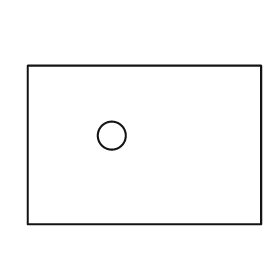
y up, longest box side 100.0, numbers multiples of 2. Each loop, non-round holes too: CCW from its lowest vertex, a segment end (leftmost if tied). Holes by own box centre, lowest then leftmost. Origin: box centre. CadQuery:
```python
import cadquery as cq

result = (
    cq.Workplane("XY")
    .moveTo(-50.0, -34.0)
    .lineTo(50.0, -34.0)
    .lineTo(50.0, 34.0)
    .lineTo(-50.0, 34.0)
    .close()
    .moveTo(-14.0, 4.0)
    .circle(6.0)
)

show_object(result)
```